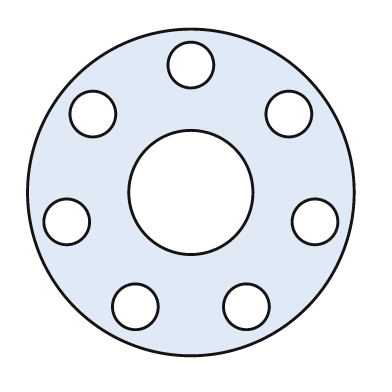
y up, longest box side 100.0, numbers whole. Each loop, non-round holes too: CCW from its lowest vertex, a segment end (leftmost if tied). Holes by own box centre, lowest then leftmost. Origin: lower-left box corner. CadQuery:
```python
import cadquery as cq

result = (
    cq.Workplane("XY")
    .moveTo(50.0, 50.0)
    .circle(50.0)
    .moveTo(33.0, 15.0)
    .circle(7.0)
    .moveTo(67.0, 15.0)
    .circle(7.0)
    .moveTo(12.0, 41.0)
    .circle(7.0)
    .moveTo(88.0, 41.0)
    .circle(7.0)
    .moveTo(50.0, 50.0)
    .circle(19.0)
    .moveTo(20.0, 74.0)
    .circle(7.0)
    .moveTo(80.0, 74.0)
    .circle(7.0)
    .moveTo(50.0, 89.0)
    .circle(7.0)
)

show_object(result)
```